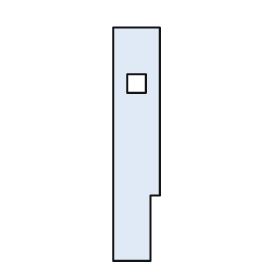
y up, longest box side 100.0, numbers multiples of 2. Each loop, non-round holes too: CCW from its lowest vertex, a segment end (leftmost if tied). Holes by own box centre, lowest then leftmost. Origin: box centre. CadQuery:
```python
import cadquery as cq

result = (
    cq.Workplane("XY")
    .moveTo(-10.0, -50.0)
    .lineTo(6.0, -50.0)
    .lineTo(6.0, -22.0)
    .lineTo(10.0, -22.0)
    .lineTo(10.0, 50.0)
    .lineTo(-10.0, 50.0)
    .close()
    .moveTo(-4.0, 22.0)
    .lineTo(4.0, 22.0)
    .lineTo(4.0, 30.0)
    .lineTo(-4.0, 30.0)
    .close()
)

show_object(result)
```